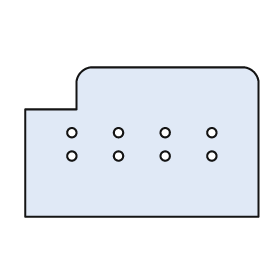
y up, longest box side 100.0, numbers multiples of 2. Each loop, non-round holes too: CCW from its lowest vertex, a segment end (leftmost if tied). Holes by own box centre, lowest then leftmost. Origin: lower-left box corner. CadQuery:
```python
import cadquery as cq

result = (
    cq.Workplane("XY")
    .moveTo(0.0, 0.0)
    .lineTo(100.0, 0.0)
    .lineTo(100.0, 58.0)
    .threePointArc((98.0, 62.0), (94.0, 64.0))
    .lineTo(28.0, 64.0)
    .threePointArc((24.0, 62.0), (22.0, 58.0))
    .lineTo(22.0, 46.0)
    .lineTo(0.0, 46.0)
    .close()
    .moveTo(20.0, 26.0)
    .circle(2.0)
    .moveTo(40.0, 26.0)
    .circle(2.0)
    .moveTo(60.0, 26.0)
    .circle(2.0)
    .moveTo(80.0, 26.0)
    .circle(2.0)
    .moveTo(20.0, 36.0)
    .circle(2.0)
    .moveTo(40.0, 36.0)
    .circle(2.0)
    .moveTo(60.0, 36.0)
    .circle(2.0)
    .moveTo(80.0, 36.0)
    .circle(2.0)
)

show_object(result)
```